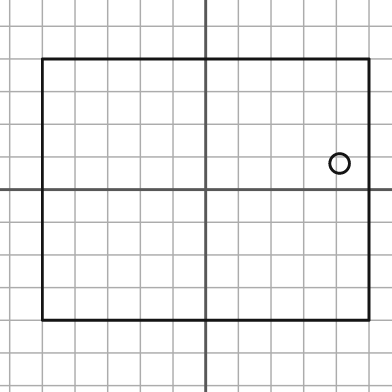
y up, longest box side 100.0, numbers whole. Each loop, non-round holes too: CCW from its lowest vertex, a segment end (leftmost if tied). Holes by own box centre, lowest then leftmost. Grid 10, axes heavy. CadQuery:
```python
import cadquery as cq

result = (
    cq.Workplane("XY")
    .moveTo(-50.0, -40.0)
    .lineTo(50.0, -40.0)
    .lineTo(50.0, 40.0)
    .lineTo(-50.0, 40.0)
    .close()
    .moveTo(41.0, 8.0)
    .circle(3.0)
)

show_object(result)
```